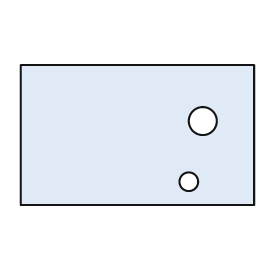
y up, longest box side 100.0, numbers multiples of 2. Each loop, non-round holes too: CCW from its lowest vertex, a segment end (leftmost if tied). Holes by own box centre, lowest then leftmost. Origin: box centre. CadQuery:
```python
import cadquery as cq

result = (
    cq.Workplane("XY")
    .moveTo(-50.0, -30.0)
    .lineTo(50.0, -30.0)
    .lineTo(50.0, 30.0)
    .lineTo(-50.0, 30.0)
    .close()
    .moveTo(22.0, -20.0)
    .circle(4.0)
    .moveTo(28.0, 6.0)
    .circle(6.0)
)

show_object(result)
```